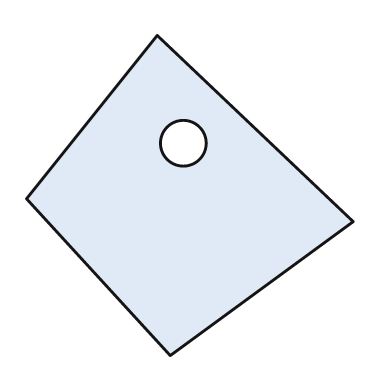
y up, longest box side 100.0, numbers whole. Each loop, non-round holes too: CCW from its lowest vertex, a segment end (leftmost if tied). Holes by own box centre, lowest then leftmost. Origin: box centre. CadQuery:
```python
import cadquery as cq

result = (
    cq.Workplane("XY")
    .moveTo(-6.0, -49.0)
    .lineTo(50.0, -8.0)
    .lineTo(-10.0, 49.0)
    .lineTo(-50.0, -1.0)
    .close()
    .moveTo(-2.0, 16.0)
    .circle(7.0)
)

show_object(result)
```